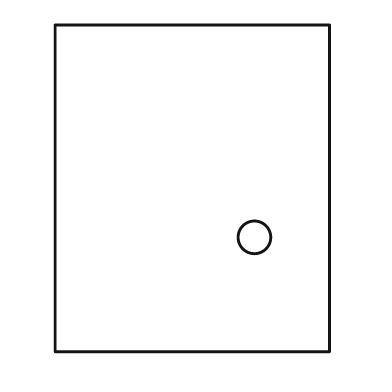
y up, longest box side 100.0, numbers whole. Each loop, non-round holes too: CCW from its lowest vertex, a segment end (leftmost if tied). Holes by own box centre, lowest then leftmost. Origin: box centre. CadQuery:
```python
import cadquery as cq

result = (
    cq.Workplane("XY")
    .moveTo(-42.0, -50.0)
    .lineTo(42.0, -50.0)
    .lineTo(42.0, 50.0)
    .lineTo(-42.0, 50.0)
    .close()
    .moveTo(19.0, -15.0)
    .circle(5.0)
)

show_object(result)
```